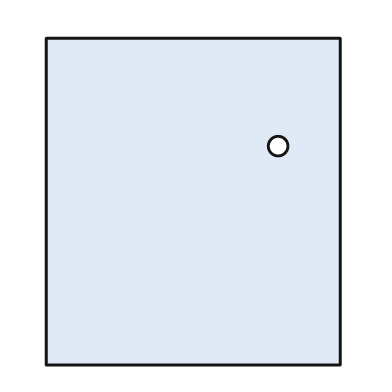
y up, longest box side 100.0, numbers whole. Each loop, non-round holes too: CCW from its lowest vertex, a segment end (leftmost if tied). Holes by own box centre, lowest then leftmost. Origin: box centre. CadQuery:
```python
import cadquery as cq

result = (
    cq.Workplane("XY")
    .moveTo(-45.0, -50.0)
    .lineTo(45.0, -50.0)
    .lineTo(45.0, 50.0)
    .lineTo(-45.0, 50.0)
    .close()
    .moveTo(26.0, 17.0)
    .circle(3.0)
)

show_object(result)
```